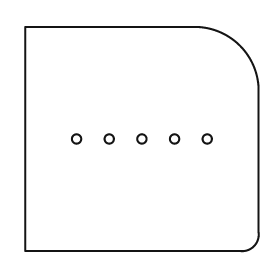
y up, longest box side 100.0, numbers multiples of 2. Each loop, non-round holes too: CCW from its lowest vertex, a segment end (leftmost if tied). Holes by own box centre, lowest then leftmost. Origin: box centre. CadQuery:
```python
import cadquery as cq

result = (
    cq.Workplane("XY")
    .moveTo(-50.0, -48.0)
    .lineTo(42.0, -48.0)
    .threePointArc((48.0, -46.0), (50.0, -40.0))
    .lineTo(50.0, 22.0)
    .threePointArc((42.0, 40.0), (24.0, 48.0))
    .lineTo(-50.0, 48.0)
    .close()
    .moveTo(-28.0, 0.0)
    .circle(2.0)
    .moveTo(-14.0, 0.0)
    .circle(2.0)
    .moveTo(0.0, 0.0)
    .circle(2.0)
    .moveTo(14.0, 0.0)
    .circle(2.0)
    .moveTo(28.0, 0.0)
    .circle(2.0)
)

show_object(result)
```